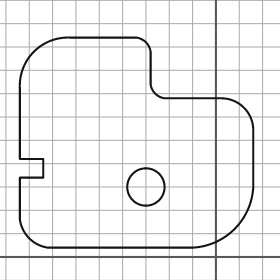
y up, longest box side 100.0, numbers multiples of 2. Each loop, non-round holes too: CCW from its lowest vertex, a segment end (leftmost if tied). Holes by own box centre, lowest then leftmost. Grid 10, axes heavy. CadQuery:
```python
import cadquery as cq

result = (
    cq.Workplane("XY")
    .moveTo(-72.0, 4.0)
    .lineTo(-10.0, 4.0)
    .threePointArc((8.0, 12.0), (16.0, 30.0))
    .lineTo(16.0, 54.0)
    .threePointArc((12.0, 64.0), (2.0, 68.0))
    .lineTo(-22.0, 68.0)
    .threePointArc((-26.0, 70.0), (-28.0, 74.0))
    .lineTo(-28.0, 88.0)
    .threePointArc((-30.0, 92.0), (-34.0, 94.0))
    .lineTo(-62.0, 94.0)
    .threePointArc((-78.0, 88.0), (-84.0, 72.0))
    .lineTo(-84.0, 42.0)
    .lineTo(-74.0, 42.0)
    .lineTo(-74.0, 34.0)
    .lineTo(-84.0, 34.0)
    .lineTo(-84.0, 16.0)
    .threePointArc((-80.0, 8.0), (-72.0, 4.0))
    .close()
    .moveTo(-30.0, 30.0)
    .circle(8.0)
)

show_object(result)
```